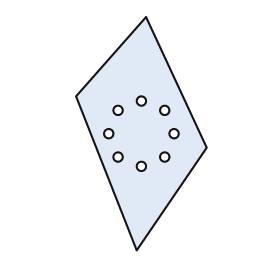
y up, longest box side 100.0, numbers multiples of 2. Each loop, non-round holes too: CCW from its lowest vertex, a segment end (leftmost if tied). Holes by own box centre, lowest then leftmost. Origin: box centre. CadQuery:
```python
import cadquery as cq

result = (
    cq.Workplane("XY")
    .moveTo(-2.0, -50.0)
    .lineTo(28.0, -6.0)
    .lineTo(2.0, 50.0)
    .lineTo(-28.0, 16.0)
    .close()
    .moveTo(0.0, -14.0)
    .circle(2.0)
    .moveTo(-10.0, -10.0)
    .circle(2.0)
    .moveTo(10.0, -10.0)
    .circle(2.0)
    .moveTo(-14.0, 0.0)
    .circle(2.0)
    .moveTo(14.0, 0.0)
    .circle(2.0)
    .moveTo(-10.0, 10.0)
    .circle(2.0)
    .moveTo(10.0, 10.0)
    .circle(2.0)
    .moveTo(0.0, 14.0)
    .circle(2.0)
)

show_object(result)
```